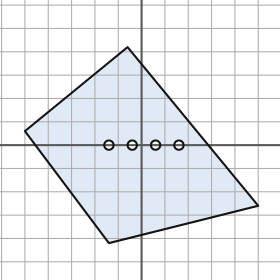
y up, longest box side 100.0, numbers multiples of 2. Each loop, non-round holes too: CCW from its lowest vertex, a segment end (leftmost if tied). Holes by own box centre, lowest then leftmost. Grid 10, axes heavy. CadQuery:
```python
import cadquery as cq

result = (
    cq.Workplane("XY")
    .moveTo(-14.0, -42.0)
    .lineTo(50.0, -26.0)
    .lineTo(-6.0, 42.0)
    .lineTo(-50.0, 6.0)
    .close()
    .moveTo(-14.0, 0.0)
    .circle(2.0)
    .moveTo(-4.0, 0.0)
    .circle(2.0)
    .moveTo(6.0, 0.0)
    .circle(2.0)
    .moveTo(16.0, 0.0)
    .circle(2.0)
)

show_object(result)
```